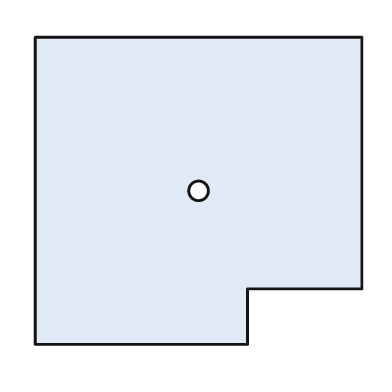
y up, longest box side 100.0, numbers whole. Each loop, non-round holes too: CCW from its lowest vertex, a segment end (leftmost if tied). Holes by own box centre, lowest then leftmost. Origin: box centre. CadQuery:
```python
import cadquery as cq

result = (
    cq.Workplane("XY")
    .moveTo(-50.0, -47.0)
    .lineTo(15.0, -47.0)
    .lineTo(15.0, -30.0)
    .lineTo(50.0, -30.0)
    .lineTo(50.0, 47.0)
    .lineTo(-50.0, 47.0)
    .close()
    .moveTo(0.0, 0.0)
    .circle(3.0)
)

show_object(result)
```